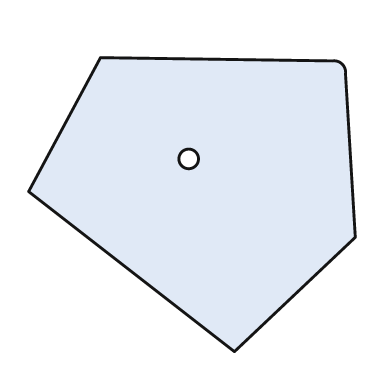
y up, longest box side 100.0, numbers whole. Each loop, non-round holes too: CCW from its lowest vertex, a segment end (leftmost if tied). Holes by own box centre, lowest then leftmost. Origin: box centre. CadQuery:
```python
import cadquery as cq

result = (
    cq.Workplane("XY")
    .moveTo(13.0, -45.0)
    .lineTo(50.0, -10.0)
    .lineTo(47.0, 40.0)
    .threePointArc((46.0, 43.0), (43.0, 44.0))
    .lineTo(-28.0, 45.0)
    .lineTo(-50.0, 4.0)
    .close()
    .moveTo(-1.0, 14.0)
    .circle(3.0)
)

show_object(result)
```